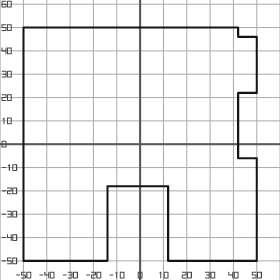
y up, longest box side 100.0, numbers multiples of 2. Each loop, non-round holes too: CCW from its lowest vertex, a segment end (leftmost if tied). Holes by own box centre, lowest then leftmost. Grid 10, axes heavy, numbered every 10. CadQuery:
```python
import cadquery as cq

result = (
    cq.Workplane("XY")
    .moveTo(-50.0, -50.0)
    .lineTo(-14.0, -50.0)
    .lineTo(-14.0, -18.0)
    .lineTo(12.0, -18.0)
    .lineTo(12.0, -50.0)
    .lineTo(50.0, -50.0)
    .lineTo(50.0, -6.0)
    .lineTo(42.0, -6.0)
    .lineTo(42.0, 22.0)
    .lineTo(50.0, 22.0)
    .lineTo(50.0, 46.0)
    .lineTo(42.0, 46.0)
    .lineTo(42.0, 50.0)
    .lineTo(-50.0, 50.0)
    .close()
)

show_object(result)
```